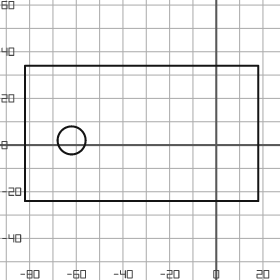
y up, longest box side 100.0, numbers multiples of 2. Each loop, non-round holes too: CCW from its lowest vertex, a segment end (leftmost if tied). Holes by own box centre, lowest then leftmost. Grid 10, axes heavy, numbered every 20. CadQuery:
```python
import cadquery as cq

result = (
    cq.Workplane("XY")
    .moveTo(-82.0, -24.0)
    .lineTo(18.0, -24.0)
    .lineTo(18.0, 34.0)
    .lineTo(-82.0, 34.0)
    .close()
    .moveTo(-62.0, 2.0)
    .circle(6.0)
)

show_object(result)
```